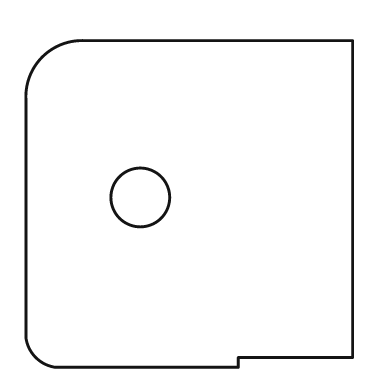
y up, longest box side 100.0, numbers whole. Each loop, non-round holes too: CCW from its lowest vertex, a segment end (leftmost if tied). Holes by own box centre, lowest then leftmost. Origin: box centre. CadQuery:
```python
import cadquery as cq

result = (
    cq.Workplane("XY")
    .moveTo(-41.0, -50.0)
    .lineTo(15.0, -50.0)
    .lineTo(15.0, -47.0)
    .lineTo(50.0, -47.0)
    .lineTo(50.0, 50.0)
    .lineTo(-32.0, 50.0)
    .threePointArc((-45.0, 45.0), (-50.0, 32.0))
    .lineTo(-50.0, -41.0)
    .threePointArc((-47.0, -47.0), (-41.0, -50.0))
    .close()
    .moveTo(-15.0, 2.0)
    .circle(9.0)
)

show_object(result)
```